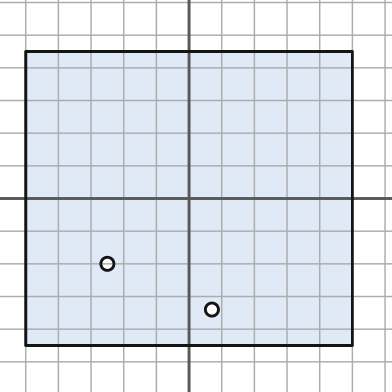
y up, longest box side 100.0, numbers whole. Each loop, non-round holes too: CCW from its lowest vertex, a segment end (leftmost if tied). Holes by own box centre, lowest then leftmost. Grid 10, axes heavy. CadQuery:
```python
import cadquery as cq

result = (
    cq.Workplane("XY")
    .moveTo(-50.0, -45.0)
    .lineTo(50.0, -45.0)
    .lineTo(50.0, 45.0)
    .lineTo(-50.0, 45.0)
    .close()
    .moveTo(7.0, -34.0)
    .circle(2.0)
    .moveTo(-25.0, -20.0)
    .circle(2.0)
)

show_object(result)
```